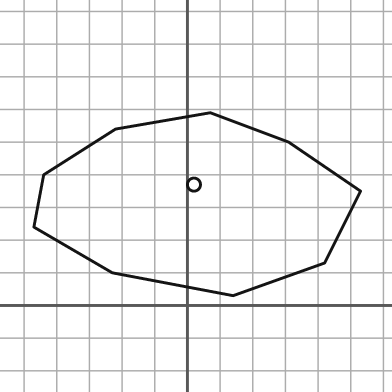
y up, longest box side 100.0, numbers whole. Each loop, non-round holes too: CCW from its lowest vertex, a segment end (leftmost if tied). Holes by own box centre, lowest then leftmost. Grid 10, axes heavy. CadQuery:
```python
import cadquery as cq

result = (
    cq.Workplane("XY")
    .moveTo(14.0, 3.0)
    .lineTo(42.0, 13.0)
    .lineTo(53.0, 35.0)
    .lineTo(31.0, 50.0)
    .lineTo(7.0, 59.0)
    .lineTo(-22.0, 54.0)
    .lineTo(-44.0, 40.0)
    .lineTo(-47.0, 24.0)
    .lineTo(-23.0, 10.0)
    .close()
    .moveTo(2.0, 37.0)
    .circle(2.0)
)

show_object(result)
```